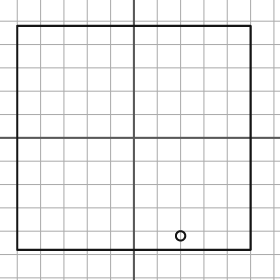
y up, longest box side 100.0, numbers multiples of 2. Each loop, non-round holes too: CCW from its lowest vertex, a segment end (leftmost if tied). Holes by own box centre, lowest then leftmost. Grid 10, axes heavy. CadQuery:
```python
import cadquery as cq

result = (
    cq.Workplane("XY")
    .moveTo(-50.0, -48.0)
    .lineTo(50.0, -48.0)
    .lineTo(50.0, 48.0)
    .lineTo(-50.0, 48.0)
    .close()
    .moveTo(20.0, -42.0)
    .circle(2.0)
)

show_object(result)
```